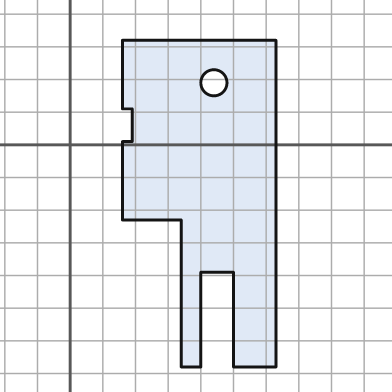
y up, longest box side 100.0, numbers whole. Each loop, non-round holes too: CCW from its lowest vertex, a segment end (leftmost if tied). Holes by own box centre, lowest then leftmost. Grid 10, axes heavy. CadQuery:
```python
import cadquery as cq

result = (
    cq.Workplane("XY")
    .moveTo(34.0, -68.0)
    .lineTo(40.0, -68.0)
    .lineTo(40.0, -39.0)
    .lineTo(50.0, -39.0)
    .lineTo(50.0, -68.0)
    .lineTo(63.0, -68.0)
    .lineTo(63.0, 32.0)
    .lineTo(16.0, 32.0)
    .lineTo(16.0, 11.0)
    .lineTo(19.0, 11.0)
    .lineTo(19.0, 1.0)
    .lineTo(16.0, 1.0)
    .lineTo(16.0, -23.0)
    .lineTo(34.0, -23.0)
    .close()
    .moveTo(44.0, 19.0)
    .circle(4.0)
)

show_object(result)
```